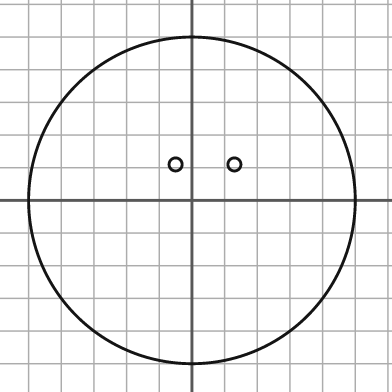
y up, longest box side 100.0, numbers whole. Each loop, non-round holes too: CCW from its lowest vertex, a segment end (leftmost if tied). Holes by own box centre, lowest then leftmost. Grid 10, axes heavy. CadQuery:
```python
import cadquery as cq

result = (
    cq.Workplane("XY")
    .moveTo(0.0, 0.0)
    .circle(50.0)
    .moveTo(-5.0, 11.0)
    .circle(2.0)
    .moveTo(13.0, 11.0)
    .circle(2.0)
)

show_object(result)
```